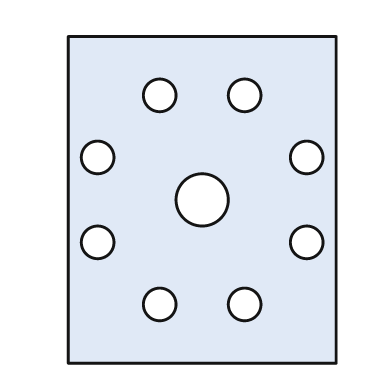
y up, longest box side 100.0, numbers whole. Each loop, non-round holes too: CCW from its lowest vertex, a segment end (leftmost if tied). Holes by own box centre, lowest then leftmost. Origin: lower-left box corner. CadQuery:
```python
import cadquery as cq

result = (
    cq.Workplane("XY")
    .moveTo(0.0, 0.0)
    .lineTo(82.0, 0.0)
    .lineTo(82.0, 100.0)
    .lineTo(0.0, 100.0)
    .close()
    .moveTo(28.0, 18.0)
    .circle(5.0)
    .moveTo(54.0, 18.0)
    .circle(5.0)
    .moveTo(9.0, 37.0)
    .circle(5.0)
    .moveTo(73.0, 37.0)
    .circle(5.0)
    .moveTo(41.0, 50.0)
    .circle(8.0)
    .moveTo(9.0, 63.0)
    .circle(5.0)
    .moveTo(73.0, 63.0)
    .circle(5.0)
    .moveTo(28.0, 82.0)
    .circle(5.0)
    .moveTo(54.0, 82.0)
    .circle(5.0)
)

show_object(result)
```